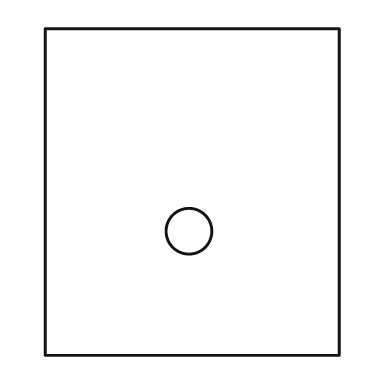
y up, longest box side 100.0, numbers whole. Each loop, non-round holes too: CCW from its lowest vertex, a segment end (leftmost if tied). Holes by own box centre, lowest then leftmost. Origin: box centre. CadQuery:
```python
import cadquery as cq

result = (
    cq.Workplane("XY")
    .moveTo(-45.0, -50.0)
    .lineTo(45.0, -50.0)
    .lineTo(45.0, 50.0)
    .lineTo(-45.0, 50.0)
    .close()
    .moveTo(-1.0, -12.0)
    .circle(7.0)
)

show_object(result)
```